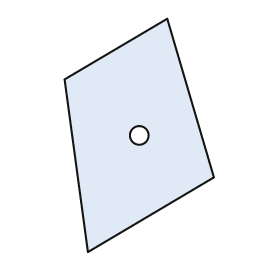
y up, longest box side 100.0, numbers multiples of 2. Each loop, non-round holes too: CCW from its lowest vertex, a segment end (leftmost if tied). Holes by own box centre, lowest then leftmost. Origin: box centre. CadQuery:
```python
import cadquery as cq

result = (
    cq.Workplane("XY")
    .moveTo(-22.0, -50.0)
    .lineTo(32.0, -18.0)
    .lineTo(12.0, 50.0)
    .lineTo(-32.0, 24.0)
    .close()
    .moveTo(0.0, 0.0)
    .circle(4.0)
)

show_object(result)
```